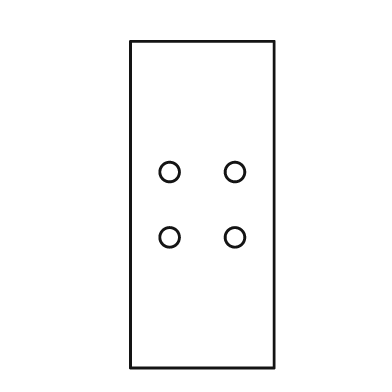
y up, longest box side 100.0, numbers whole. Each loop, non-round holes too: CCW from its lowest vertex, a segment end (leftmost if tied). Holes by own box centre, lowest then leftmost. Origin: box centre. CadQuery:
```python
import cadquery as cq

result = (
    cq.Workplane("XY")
    .moveTo(-22.0, -50.0)
    .lineTo(22.0, -50.0)
    .lineTo(22.0, 50.0)
    .lineTo(-22.0, 50.0)
    .close()
    .moveTo(-10.0, -10.0)
    .circle(3.0)
    .moveTo(10.0, -10.0)
    .circle(3.0)
    .moveTo(-10.0, 10.0)
    .circle(3.0)
    .moveTo(10.0, 10.0)
    .circle(3.0)
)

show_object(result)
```